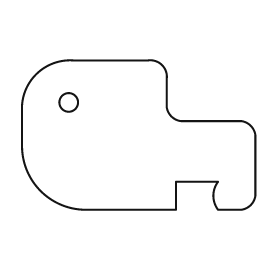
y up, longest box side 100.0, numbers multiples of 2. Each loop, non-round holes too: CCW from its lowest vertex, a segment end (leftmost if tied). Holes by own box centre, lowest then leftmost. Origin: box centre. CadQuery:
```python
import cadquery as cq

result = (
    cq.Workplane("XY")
    .moveTo(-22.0, -32.0)
    .lineTo(16.0, -32.0)
    .lineTo(16.0, -20.0)
    .lineTo(34.0, -20.0)
    .threePointArc((32.0, -26.0), (34.0, -32.0))
    .lineTo(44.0, -32.0)
    .threePointArc((48.0, -30.0), (50.0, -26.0))
    .lineTo(50.0, 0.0)
    .threePointArc((48.0, 4.0), (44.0, 6.0))
    .lineTo(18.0, 6.0)
    .threePointArc((14.0, 8.0), (12.0, 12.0))
    .lineTo(12.0, 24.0)
    .threePointArc((10.0, 30.0), (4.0, 32.0))
    .lineTo(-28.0, 32.0)
    .threePointArc((-44.0, 26.0), (-50.0, 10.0))
    .lineTo(-50.0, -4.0)
    .threePointArc((-42.0, -24.0), (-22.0, -32.0))
    .close()
    .moveTo(-30.0, 14.0)
    .circle(4.0)
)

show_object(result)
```